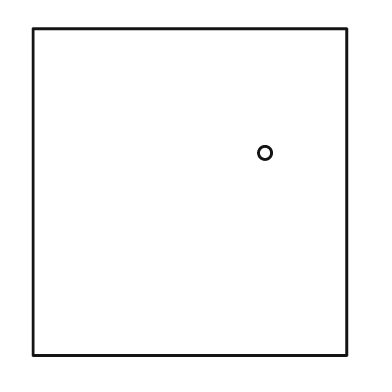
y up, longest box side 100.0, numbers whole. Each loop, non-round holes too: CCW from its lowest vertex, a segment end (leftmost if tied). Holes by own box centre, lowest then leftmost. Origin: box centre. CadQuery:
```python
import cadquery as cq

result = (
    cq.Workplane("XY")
    .moveTo(-48.0, -50.0)
    .lineTo(48.0, -50.0)
    .lineTo(48.0, 50.0)
    .lineTo(-48.0, 50.0)
    .close()
    .moveTo(23.0, 12.0)
    .circle(2.0)
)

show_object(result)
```